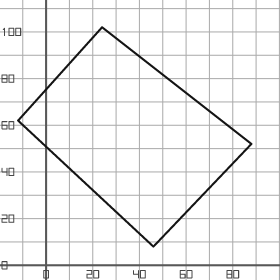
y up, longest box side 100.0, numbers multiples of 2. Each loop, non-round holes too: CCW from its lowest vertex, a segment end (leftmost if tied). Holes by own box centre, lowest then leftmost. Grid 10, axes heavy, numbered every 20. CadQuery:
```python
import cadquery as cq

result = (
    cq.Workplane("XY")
    .moveTo(46.0, 8.0)
    .lineTo(88.0, 52.0)
    .lineTo(24.0, 102.0)
    .lineTo(-12.0, 62.0)
    .close()
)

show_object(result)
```